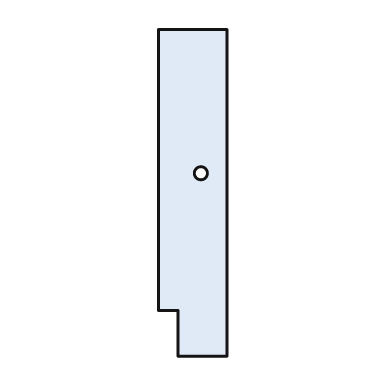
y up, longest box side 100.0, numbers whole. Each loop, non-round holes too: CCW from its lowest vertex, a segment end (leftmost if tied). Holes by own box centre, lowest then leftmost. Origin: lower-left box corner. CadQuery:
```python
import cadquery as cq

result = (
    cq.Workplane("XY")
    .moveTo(6.0, 0.0)
    .lineTo(21.0, 0.0)
    .lineTo(21.0, 100.0)
    .lineTo(0.0, 100.0)
    .lineTo(0.0, 14.0)
    .lineTo(6.0, 14.0)
    .close()
    .moveTo(13.0, 56.0)
    .circle(2.0)
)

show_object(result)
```